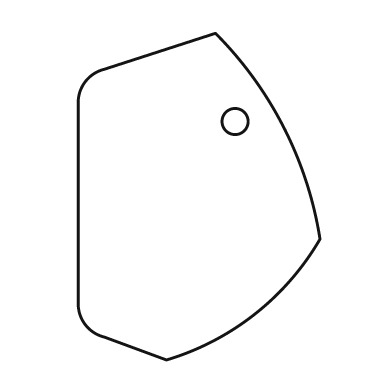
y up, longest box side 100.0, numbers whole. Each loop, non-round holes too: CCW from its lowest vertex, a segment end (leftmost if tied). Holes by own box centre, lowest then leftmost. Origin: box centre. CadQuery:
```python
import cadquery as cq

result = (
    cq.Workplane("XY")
    .moveTo(-10.0, -50.0)
    .threePointArc((17.0, -36.0), (37.0, -13.0))
    .threePointArc((26.0, 21.0), (5.0, 50.0))
    .lineTo(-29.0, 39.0)
    .threePointArc((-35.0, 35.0), (-37.0, 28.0))
    .lineTo(-37.0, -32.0)
    .threePointArc((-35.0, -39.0), (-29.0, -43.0))
    .close()
    .moveTo(11.0, 23.0)
    .circle(4.0)
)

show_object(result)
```